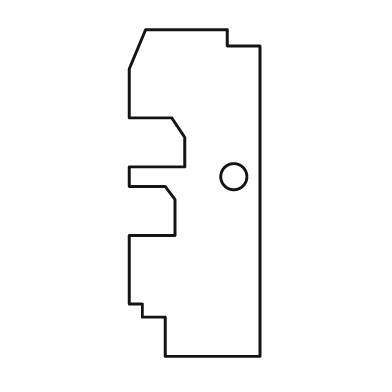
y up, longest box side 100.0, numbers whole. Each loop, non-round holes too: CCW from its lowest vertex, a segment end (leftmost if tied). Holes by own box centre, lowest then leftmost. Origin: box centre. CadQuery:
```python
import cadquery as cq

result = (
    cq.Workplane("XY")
    .moveTo(-9.0, -50.0)
    .lineTo(20.0, -50.0)
    .lineTo(20.0, 45.0)
    .lineTo(10.0, 45.0)
    .lineTo(10.0, 50.0)
    .lineTo(-15.0, 50.0)
    .lineTo(-20.0, 38.0)
    .lineTo(-20.0, 23.0)
    .lineTo(-7.0, 23.0)
    .lineTo(-3.0, 17.0)
    .lineTo(-3.0, 8.0)
    .lineTo(-20.0, 8.0)
    .lineTo(-20.0, 2.0)
    .lineTo(-9.0, 2.0)
    .lineTo(-6.0, -2.0)
    .lineTo(-6.0, -13.0)
    .lineTo(-20.0, -13.0)
    .lineTo(-20.0, -34.0)
    .lineTo(-16.0, -34.0)
    .lineTo(-16.0, -38.0)
    .lineTo(-9.0, -38.0)
    .close()
    .moveTo(12.0, 5.0)
    .circle(4.0)
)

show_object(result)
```